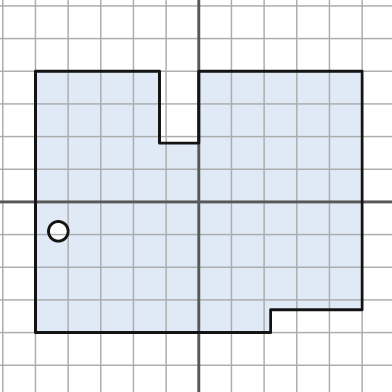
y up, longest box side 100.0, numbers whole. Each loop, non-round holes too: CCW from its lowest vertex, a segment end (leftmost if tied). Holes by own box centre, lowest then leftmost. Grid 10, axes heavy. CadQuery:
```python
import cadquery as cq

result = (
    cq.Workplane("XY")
    .moveTo(-50.0, -40.0)
    .lineTo(22.0, -40.0)
    .lineTo(22.0, -33.0)
    .lineTo(50.0, -33.0)
    .lineTo(50.0, 40.0)
    .lineTo(0.0, 40.0)
    .lineTo(0.0, 18.0)
    .lineTo(-12.0, 18.0)
    .lineTo(-12.0, 40.0)
    .lineTo(-50.0, 40.0)
    .close()
    .moveTo(-43.0, -9.0)
    .circle(3.0)
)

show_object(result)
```